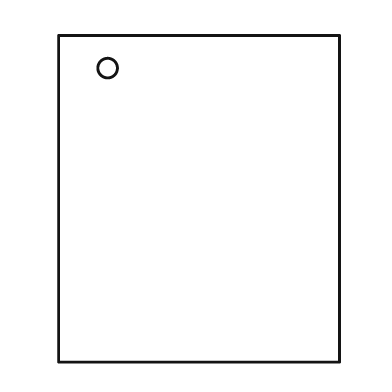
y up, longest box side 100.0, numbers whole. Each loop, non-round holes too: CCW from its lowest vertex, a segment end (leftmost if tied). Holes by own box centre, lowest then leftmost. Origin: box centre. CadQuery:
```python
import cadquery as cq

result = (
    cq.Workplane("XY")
    .moveTo(-43.0, -50.0)
    .lineTo(43.0, -50.0)
    .lineTo(43.0, 50.0)
    .lineTo(-43.0, 50.0)
    .close()
    .moveTo(-28.0, 40.0)
    .circle(3.0)
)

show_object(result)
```